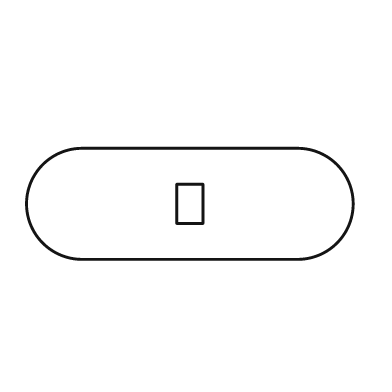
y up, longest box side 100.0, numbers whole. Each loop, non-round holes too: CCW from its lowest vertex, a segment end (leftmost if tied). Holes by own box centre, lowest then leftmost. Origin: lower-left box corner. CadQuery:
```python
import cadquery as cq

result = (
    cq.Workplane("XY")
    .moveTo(17.0, 0.0)
    .lineTo(83.0, 0.0)
    .threePointArc((100.0, 17.0), (83.0, 34.0))
    .lineTo(17.0, 34.0)
    .threePointArc((0.0, 17.0), (17.0, 0.0))
    .close()
    .moveTo(46.0, 11.0)
    .lineTo(54.0, 11.0)
    .lineTo(54.0, 23.0)
    .lineTo(46.0, 23.0)
    .close()
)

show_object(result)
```